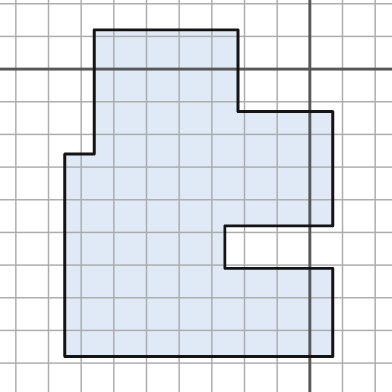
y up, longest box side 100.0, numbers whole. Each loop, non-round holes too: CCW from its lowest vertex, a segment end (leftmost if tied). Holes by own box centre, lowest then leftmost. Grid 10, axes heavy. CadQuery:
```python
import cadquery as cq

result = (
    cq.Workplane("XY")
    .moveTo(-75.0, -88.0)
    .lineTo(7.0, -88.0)
    .lineTo(7.0, -61.0)
    .lineTo(-26.0, -61.0)
    .lineTo(-26.0, -48.0)
    .lineTo(7.0, -48.0)
    .lineTo(7.0, -13.0)
    .lineTo(-22.0, -13.0)
    .lineTo(-22.0, 12.0)
    .lineTo(-66.0, 12.0)
    .lineTo(-66.0, -26.0)
    .lineTo(-75.0, -26.0)
    .close()
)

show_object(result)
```